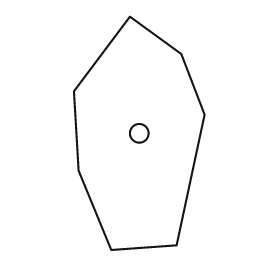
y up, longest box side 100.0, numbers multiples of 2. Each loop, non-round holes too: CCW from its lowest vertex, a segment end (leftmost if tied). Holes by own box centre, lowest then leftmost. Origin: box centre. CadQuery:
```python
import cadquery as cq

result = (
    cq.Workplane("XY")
    .moveTo(-12.0, -50.0)
    .lineTo(16.0, -48.0)
    .lineTo(28.0, 8.0)
    .lineTo(18.0, 34.0)
    .lineTo(-4.0, 50.0)
    .lineTo(-28.0, 18.0)
    .lineTo(-26.0, -16.0)
    .close()
    .moveTo(0.0, 0.0)
    .circle(4.0)
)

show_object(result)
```